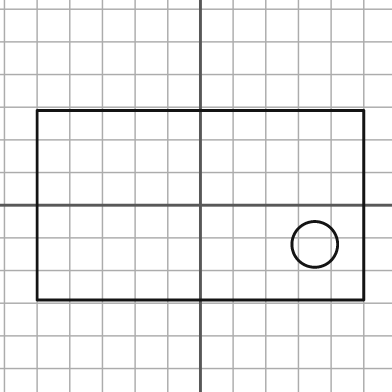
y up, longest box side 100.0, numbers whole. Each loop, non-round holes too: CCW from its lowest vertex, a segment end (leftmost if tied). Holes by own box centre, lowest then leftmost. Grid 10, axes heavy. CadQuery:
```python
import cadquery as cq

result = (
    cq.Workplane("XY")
    .moveTo(-50.0, -29.0)
    .lineTo(50.0, -29.0)
    .lineTo(50.0, 29.0)
    .lineTo(-50.0, 29.0)
    .close()
    .moveTo(35.0, -12.0)
    .circle(7.0)
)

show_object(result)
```